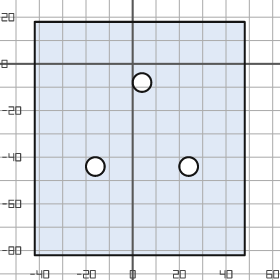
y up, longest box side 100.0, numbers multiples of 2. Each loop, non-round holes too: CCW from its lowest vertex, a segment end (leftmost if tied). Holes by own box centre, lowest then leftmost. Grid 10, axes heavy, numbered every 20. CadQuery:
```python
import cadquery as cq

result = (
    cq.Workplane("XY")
    .moveTo(-42.0, -82.0)
    .lineTo(48.0, -82.0)
    .lineTo(48.0, 18.0)
    .lineTo(-42.0, 18.0)
    .close()
    .moveTo(-16.0, -44.0)
    .circle(4.0)
    .moveTo(24.0, -44.0)
    .circle(4.0)
    .moveTo(4.0, -8.0)
    .circle(4.0)
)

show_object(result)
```